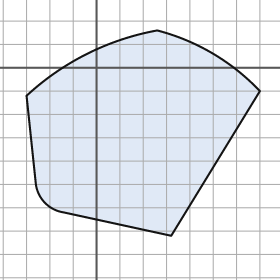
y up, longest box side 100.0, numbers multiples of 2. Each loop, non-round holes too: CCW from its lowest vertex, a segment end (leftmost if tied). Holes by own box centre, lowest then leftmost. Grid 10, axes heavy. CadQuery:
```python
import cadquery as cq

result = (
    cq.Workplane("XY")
    .moveTo(32.0, -72.0)
    .lineTo(70.0, -10.0)
    .threePointArc((50.0, 6.0), (26.0, 16.0))
    .threePointArc((-4.0, 6.0), (-30.0, -12.0))
    .lineTo(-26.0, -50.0)
    .threePointArc((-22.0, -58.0), (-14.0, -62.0))
    .close()
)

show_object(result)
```